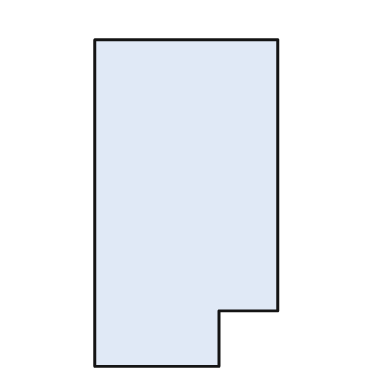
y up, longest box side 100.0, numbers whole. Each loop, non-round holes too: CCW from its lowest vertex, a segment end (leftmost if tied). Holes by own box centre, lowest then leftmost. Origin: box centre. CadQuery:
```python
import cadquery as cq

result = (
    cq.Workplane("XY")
    .moveTo(-28.0, -50.0)
    .lineTo(10.0, -50.0)
    .lineTo(10.0, -33.0)
    .lineTo(28.0, -33.0)
    .lineTo(28.0, 50.0)
    .lineTo(-28.0, 50.0)
    .close()
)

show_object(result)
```